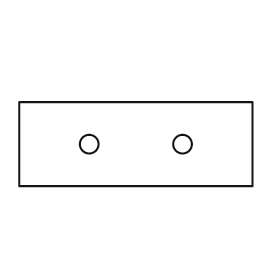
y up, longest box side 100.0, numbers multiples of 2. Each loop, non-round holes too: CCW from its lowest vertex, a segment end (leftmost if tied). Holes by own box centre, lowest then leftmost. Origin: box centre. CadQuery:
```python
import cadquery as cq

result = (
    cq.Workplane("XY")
    .moveTo(-50.0, -18.0)
    .lineTo(50.0, -18.0)
    .lineTo(50.0, 18.0)
    .lineTo(-50.0, 18.0)
    .close()
    .moveTo(-20.0, 0.0)
    .circle(4.0)
    .moveTo(20.0, 0.0)
    .circle(4.0)
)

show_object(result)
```